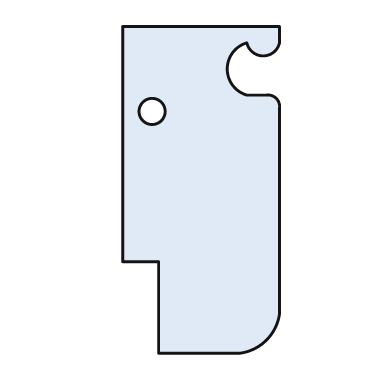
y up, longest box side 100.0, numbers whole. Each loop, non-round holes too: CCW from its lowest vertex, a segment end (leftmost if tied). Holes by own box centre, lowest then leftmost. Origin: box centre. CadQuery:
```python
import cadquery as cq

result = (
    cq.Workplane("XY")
    .moveTo(-13.0, -50.0)
    .lineTo(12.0, -50.0)
    .threePointArc((20.0, -46.0), (24.0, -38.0))
    .lineTo(24.0, 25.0)
    .threePointArc((23.0, 28.0), (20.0, 29.0))
    .lineTo(14.0, 29.0)
    .threePointArc((8.0, 37.0), (14.0, 45.0))
    .threePointArc((19.0, 41.0), (24.0, 45.0))
    .lineTo(24.0, 50.0)
    .lineTo(-24.0, 50.0)
    .lineTo(-24.0, -22.0)
    .lineTo(-13.0, -22.0)
    .close()
    .moveTo(-15.0, 24.0)
    .circle(4.0)
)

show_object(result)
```